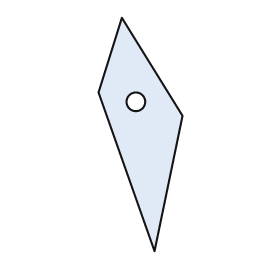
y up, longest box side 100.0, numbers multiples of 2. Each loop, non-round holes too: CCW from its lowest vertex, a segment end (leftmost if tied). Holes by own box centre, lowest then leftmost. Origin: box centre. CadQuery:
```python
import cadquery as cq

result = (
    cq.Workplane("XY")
    .moveTo(6.0, -50.0)
    .lineTo(18.0, 8.0)
    .lineTo(-8.0, 50.0)
    .lineTo(-18.0, 18.0)
    .close()
    .moveTo(-2.0, 14.0)
    .circle(4.0)
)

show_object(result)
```